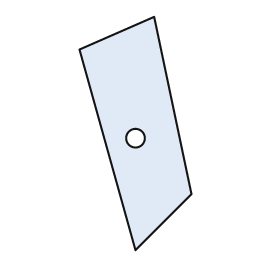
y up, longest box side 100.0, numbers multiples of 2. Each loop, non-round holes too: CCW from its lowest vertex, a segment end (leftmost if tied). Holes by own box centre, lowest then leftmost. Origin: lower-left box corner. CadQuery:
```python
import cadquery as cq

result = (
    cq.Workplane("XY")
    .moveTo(24.0, 0.0)
    .lineTo(48.0, 24.0)
    .lineTo(32.0, 100.0)
    .lineTo(0.0, 86.0)
    .close()
    .moveTo(24.0, 48.0)
    .circle(4.0)
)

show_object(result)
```